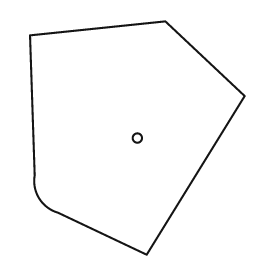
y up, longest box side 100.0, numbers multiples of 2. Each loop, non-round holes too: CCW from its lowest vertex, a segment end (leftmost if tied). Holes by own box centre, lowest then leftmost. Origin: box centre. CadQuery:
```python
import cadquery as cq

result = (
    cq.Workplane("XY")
    .moveTo(4.0, -50.0)
    .lineTo(46.0, 18.0)
    .lineTo(12.0, 50.0)
    .lineTo(-46.0, 44.0)
    .lineTo(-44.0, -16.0)
    .threePointArc((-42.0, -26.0), (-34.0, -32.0))
    .close()
    .moveTo(0.0, 0.0)
    .circle(2.0)
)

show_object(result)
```